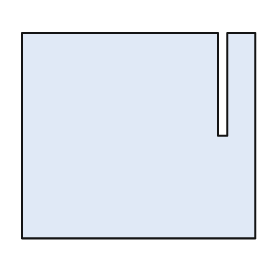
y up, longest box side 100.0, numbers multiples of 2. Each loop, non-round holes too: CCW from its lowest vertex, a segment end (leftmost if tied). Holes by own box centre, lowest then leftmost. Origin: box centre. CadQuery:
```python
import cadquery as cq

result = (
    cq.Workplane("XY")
    .moveTo(-50.0, -44.0)
    .lineTo(50.0, -44.0)
    .lineTo(50.0, 44.0)
    .lineTo(38.0, 44.0)
    .lineTo(38.0, 0.0)
    .lineTo(34.0, 0.0)
    .lineTo(34.0, 44.0)
    .lineTo(-50.0, 44.0)
    .close()
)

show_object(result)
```